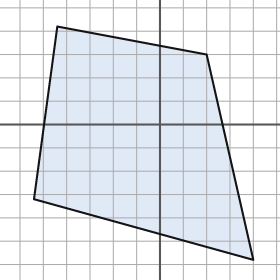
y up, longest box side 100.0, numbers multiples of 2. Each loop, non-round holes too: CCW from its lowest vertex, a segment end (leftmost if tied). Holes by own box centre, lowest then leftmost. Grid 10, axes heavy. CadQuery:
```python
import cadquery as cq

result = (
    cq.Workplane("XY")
    .moveTo(40.0, -58.0)
    .lineTo(20.0, 30.0)
    .lineTo(-44.0, 42.0)
    .lineTo(-54.0, -32.0)
    .close()
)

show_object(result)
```